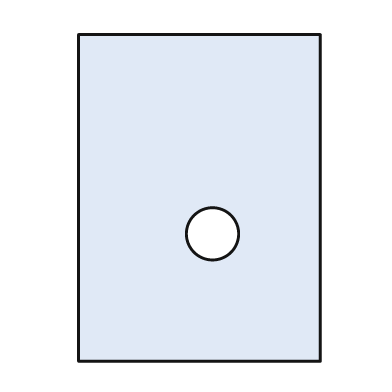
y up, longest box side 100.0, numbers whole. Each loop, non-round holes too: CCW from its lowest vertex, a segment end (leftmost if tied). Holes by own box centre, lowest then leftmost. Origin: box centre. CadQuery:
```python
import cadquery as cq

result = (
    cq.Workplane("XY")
    .moveTo(-37.0, -50.0)
    .lineTo(37.0, -50.0)
    .lineTo(37.0, 50.0)
    .lineTo(-37.0, 50.0)
    .close()
    .moveTo(4.0, -11.0)
    .circle(8.0)
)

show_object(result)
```